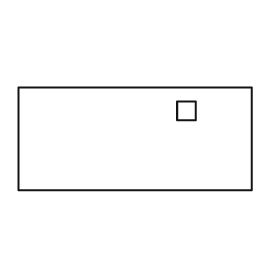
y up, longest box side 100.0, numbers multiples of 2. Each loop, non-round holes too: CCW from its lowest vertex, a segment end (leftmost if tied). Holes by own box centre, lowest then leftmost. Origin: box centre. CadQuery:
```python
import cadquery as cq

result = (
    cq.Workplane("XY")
    .moveTo(-50.0, -22.0)
    .lineTo(50.0, -22.0)
    .lineTo(50.0, 22.0)
    .lineTo(-50.0, 22.0)
    .close()
    .moveTo(18.0, 8.0)
    .lineTo(26.0, 8.0)
    .lineTo(26.0, 16.0)
    .lineTo(18.0, 16.0)
    .close()
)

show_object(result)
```